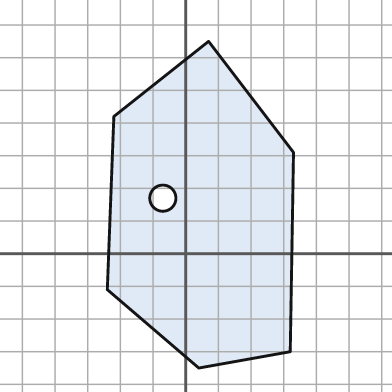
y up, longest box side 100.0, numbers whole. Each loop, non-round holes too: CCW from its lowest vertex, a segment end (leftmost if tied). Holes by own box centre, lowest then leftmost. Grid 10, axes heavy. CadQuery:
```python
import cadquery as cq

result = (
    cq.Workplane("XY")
    .moveTo(4.0, -35.0)
    .lineTo(32.0, -30.0)
    .lineTo(33.0, 31.0)
    .lineTo(7.0, 65.0)
    .lineTo(-22.0, 42.0)
    .lineTo(-24.0, -11.0)
    .close()
    .moveTo(-7.0, 17.0)
    .circle(4.0)
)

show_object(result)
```